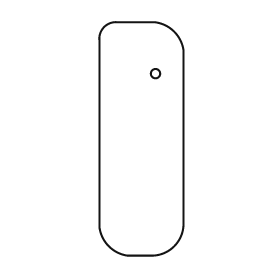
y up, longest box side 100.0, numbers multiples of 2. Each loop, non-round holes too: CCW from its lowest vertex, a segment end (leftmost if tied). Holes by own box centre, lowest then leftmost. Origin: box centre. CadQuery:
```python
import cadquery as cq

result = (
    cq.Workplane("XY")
    .moveTo(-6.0, -50.0)
    .lineTo(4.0, -50.0)
    .threePointArc((14.0, -46.0), (18.0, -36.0))
    .lineTo(18.0, 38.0)
    .threePointArc((14.0, 46.0), (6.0, 50.0))
    .lineTo(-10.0, 50.0)
    .threePointArc((-16.0, 48.0), (-18.0, 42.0))
    .lineTo(-18.0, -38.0)
    .threePointArc((-14.0, -46.0), (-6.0, -50.0))
    .close()
    .moveTo(6.0, 28.0)
    .circle(2.0)
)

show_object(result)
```